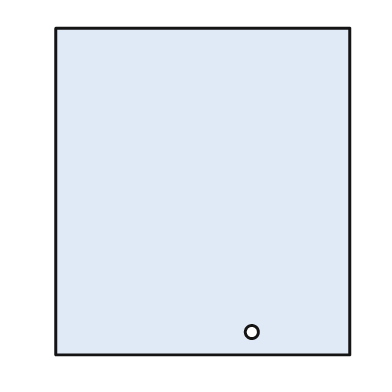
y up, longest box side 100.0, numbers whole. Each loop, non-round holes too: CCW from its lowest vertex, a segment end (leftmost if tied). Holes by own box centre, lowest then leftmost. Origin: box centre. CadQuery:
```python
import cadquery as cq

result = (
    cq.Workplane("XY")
    .moveTo(-45.0, -50.0)
    .lineTo(45.0, -50.0)
    .lineTo(45.0, 50.0)
    .lineTo(-45.0, 50.0)
    .close()
    .moveTo(15.0, -43.0)
    .circle(2.0)
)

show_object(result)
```